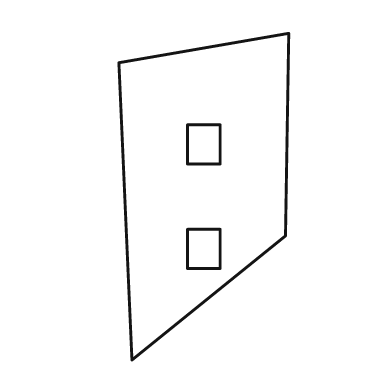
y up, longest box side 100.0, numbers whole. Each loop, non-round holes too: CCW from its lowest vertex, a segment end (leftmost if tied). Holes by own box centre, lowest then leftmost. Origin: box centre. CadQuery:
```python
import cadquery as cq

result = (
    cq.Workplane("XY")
    .moveTo(-22.0, -50.0)
    .lineTo(25.0, -12.0)
    .lineTo(26.0, 50.0)
    .lineTo(-26.0, 41.0)
    .close()
    .moveTo(-5.0, -22.0)
    .lineTo(5.0, -22.0)
    .lineTo(5.0, -10.0)
    .lineTo(-5.0, -10.0)
    .close()
    .moveTo(-5.0, 10.0)
    .lineTo(5.0, 10.0)
    .lineTo(5.0, 22.0)
    .lineTo(-5.0, 22.0)
    .close()
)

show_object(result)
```